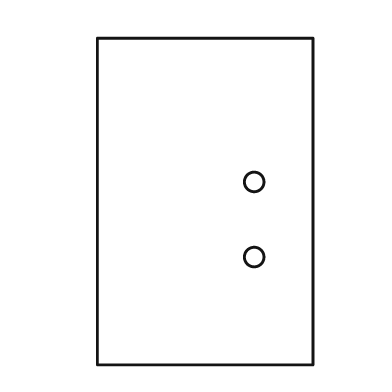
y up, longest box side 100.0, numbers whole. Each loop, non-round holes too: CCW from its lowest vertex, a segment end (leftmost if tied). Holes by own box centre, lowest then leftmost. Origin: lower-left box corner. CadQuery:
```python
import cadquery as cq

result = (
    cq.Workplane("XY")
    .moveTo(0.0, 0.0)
    .lineTo(66.0, 0.0)
    .lineTo(66.0, 100.0)
    .lineTo(0.0, 100.0)
    .close()
    .moveTo(48.0, 33.0)
    .circle(3.0)
    .moveTo(48.0, 56.0)
    .circle(3.0)
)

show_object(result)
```